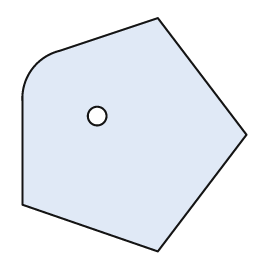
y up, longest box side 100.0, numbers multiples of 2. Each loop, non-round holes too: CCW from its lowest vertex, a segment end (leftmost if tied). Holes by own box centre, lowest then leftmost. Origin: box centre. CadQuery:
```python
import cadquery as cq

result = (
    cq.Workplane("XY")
    .moveTo(10.0, -50.0)
    .lineTo(48.0, 0.0)
    .lineTo(10.0, 50.0)
    .lineTo(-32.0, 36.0)
    .threePointArc((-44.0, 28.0), (-48.0, 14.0))
    .lineTo(-48.0, -30.0)
    .close()
    .moveTo(-16.0, 8.0)
    .circle(4.0)
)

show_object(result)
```